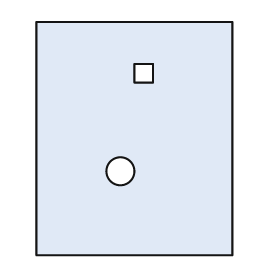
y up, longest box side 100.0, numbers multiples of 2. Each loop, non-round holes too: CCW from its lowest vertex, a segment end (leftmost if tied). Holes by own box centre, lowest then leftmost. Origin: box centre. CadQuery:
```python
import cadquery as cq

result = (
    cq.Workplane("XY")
    .moveTo(-42.0, -50.0)
    .lineTo(42.0, -50.0)
    .lineTo(42.0, 50.0)
    .lineTo(-42.0, 50.0)
    .close()
    .moveTo(-6.0, -14.0)
    .circle(6.0)
    .moveTo(0.0, 24.0)
    .lineTo(8.0, 24.0)
    .lineTo(8.0, 32.0)
    .lineTo(0.0, 32.0)
    .close()
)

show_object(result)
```